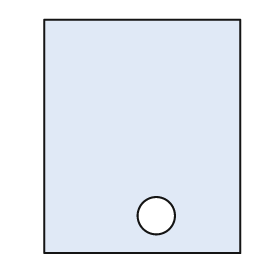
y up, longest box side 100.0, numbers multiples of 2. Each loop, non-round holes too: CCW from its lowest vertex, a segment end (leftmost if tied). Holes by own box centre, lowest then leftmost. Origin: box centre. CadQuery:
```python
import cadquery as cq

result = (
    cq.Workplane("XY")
    .moveTo(-42.0, -50.0)
    .lineTo(42.0, -50.0)
    .lineTo(42.0, 50.0)
    .lineTo(-42.0, 50.0)
    .close()
    .moveTo(6.0, -34.0)
    .circle(8.0)
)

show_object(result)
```